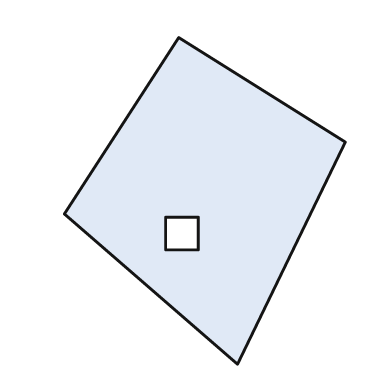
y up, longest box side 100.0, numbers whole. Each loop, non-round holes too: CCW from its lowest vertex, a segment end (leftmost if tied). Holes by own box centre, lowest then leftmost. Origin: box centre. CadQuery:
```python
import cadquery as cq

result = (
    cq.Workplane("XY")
    .moveTo(10.0, -50.0)
    .lineTo(43.0, 18.0)
    .lineTo(-8.0, 50.0)
    .lineTo(-43.0, -4.0)
    .close()
    .moveTo(-12.0, -15.0)
    .lineTo(-2.0, -15.0)
    .lineTo(-2.0, -5.0)
    .lineTo(-12.0, -5.0)
    .close()
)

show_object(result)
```